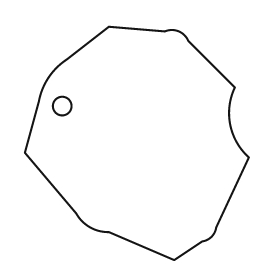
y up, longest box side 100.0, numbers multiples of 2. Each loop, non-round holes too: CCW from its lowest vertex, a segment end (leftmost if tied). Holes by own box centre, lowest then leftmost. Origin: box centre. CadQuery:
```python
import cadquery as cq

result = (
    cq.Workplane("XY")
    .moveTo(16.0, -50.0)
    .lineTo(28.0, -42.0)
    .threePointArc((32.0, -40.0), (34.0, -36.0))
    .lineTo(48.0, -6.0)
    .threePointArc((40.0, 8.0), (42.0, 24.0))
    .lineTo(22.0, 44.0)
    .threePointArc((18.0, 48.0), (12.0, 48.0))
    .lineTo(-12.0, 50.0)
    .lineTo(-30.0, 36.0)
    .threePointArc((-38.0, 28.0), (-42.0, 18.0))
    .lineTo(-48.0, -4.0)
    .lineTo(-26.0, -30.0)
    .threePointArc((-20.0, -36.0), (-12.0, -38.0))
    .close()
    .moveTo(-32.0, 16.0)
    .circle(4.0)
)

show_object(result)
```